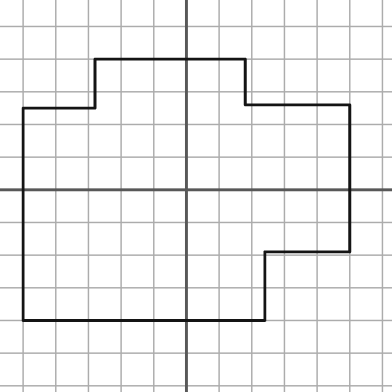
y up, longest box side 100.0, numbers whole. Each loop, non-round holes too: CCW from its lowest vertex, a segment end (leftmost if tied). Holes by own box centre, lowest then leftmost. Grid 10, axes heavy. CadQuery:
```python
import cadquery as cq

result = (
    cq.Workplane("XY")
    .moveTo(-50.0, -40.0)
    .lineTo(24.0, -40.0)
    .lineTo(24.0, -19.0)
    .lineTo(50.0, -19.0)
    .lineTo(50.0, 26.0)
    .lineTo(18.0, 26.0)
    .lineTo(18.0, 40.0)
    .lineTo(-28.0, 40.0)
    .lineTo(-28.0, 25.0)
    .lineTo(-50.0, 25.0)
    .close()
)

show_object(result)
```